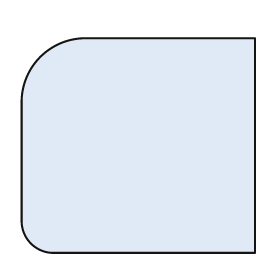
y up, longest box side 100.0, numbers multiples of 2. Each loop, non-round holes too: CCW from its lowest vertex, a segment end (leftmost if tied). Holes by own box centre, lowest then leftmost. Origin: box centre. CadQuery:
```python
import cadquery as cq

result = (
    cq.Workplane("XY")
    .moveTo(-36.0, -46.0)
    .lineTo(50.0, -46.0)
    .lineTo(50.0, 46.0)
    .lineTo(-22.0, 46.0)
    .threePointArc((-42.0, 38.0), (-50.0, 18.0))
    .lineTo(-50.0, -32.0)
    .threePointArc((-46.0, -42.0), (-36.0, -46.0))
    .close()
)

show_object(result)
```